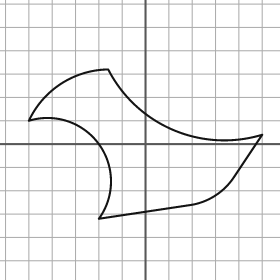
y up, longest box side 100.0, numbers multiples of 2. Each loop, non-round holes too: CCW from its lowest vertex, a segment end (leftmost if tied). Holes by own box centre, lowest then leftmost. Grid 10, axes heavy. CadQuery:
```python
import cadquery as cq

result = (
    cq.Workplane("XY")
    .moveTo(-20.0, -32.0)
    .lineTo(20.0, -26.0)
    .threePointArc((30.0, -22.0), (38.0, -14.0))
    .lineTo(50.0, 4.0)
    .threePointArc((12.0, 6.0), (-16.0, 32.0))
    .threePointArc((-36.0, 26.0), (-50.0, 10.0))
    .threePointArc((-20.0, 0.0), (-20.0, -32.0))
    .close()
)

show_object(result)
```